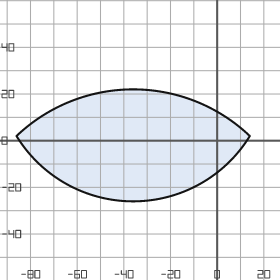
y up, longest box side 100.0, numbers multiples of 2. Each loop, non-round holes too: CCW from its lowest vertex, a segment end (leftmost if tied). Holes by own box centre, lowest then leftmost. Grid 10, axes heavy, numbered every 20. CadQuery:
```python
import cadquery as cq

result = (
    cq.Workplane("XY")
    .moveTo(-86.0, 2.0)
    .threePointArc((-36.0, -26.0), (14.0, 2.0))
    .threePointArc((-36.0, 22.0), (-86.0, 2.0))
    .close()
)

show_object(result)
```